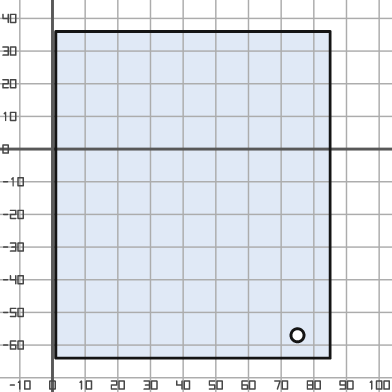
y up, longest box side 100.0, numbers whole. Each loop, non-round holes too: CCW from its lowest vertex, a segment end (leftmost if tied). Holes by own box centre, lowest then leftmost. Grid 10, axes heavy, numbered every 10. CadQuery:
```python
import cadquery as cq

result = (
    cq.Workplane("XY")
    .moveTo(1.0, -64.0)
    .lineTo(85.0, -64.0)
    .lineTo(85.0, 36.0)
    .lineTo(1.0, 36.0)
    .close()
    .moveTo(75.0, -57.0)
    .circle(2.0)
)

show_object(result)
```